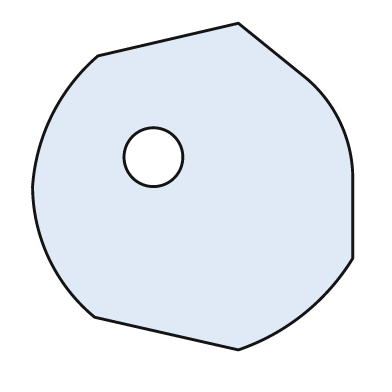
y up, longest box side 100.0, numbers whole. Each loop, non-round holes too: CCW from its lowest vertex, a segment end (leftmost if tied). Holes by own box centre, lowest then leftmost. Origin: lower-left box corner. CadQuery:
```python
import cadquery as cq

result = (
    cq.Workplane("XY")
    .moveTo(63.0, 0.0)
    .threePointArc((83.0, 11.0), (98.0, 28.0))
    .lineTo(98.0, 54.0)
    .threePointArc((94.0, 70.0), (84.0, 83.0))
    .lineTo(63.0, 100.0)
    .lineTo(20.0, 90.0)
    .threePointArc((6.0, 72.0), (0.0, 50.0))
    .threePointArc((5.0, 28.0), (19.0, 10.0))
    .close()
    .moveTo(37.0, 59.0)
    .circle(9.0)
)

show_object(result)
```